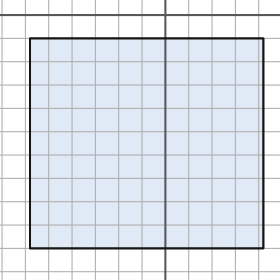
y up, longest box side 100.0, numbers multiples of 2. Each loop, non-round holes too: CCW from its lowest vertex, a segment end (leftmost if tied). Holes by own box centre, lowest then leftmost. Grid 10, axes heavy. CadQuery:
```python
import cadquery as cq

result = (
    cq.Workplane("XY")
    .moveTo(-58.0, -100.0)
    .lineTo(42.0, -100.0)
    .lineTo(42.0, -10.0)
    .lineTo(-58.0, -10.0)
    .close()
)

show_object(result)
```